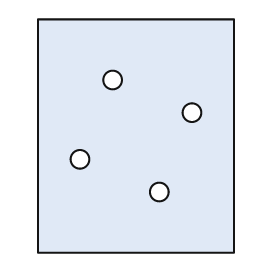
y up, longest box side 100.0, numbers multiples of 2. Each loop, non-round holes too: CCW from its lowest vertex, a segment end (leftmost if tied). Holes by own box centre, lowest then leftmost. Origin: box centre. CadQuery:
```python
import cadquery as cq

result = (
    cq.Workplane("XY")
    .moveTo(-42.0, -50.0)
    .lineTo(42.0, -50.0)
    .lineTo(42.0, 50.0)
    .lineTo(-42.0, 50.0)
    .close()
    .moveTo(10.0, -24.0)
    .circle(4.0)
    .moveTo(-24.0, -10.0)
    .circle(4.0)
    .moveTo(24.0, 10.0)
    .circle(4.0)
    .moveTo(-10.0, 24.0)
    .circle(4.0)
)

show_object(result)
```